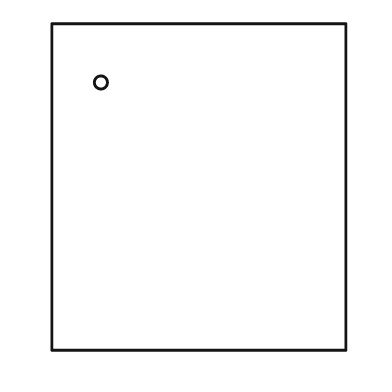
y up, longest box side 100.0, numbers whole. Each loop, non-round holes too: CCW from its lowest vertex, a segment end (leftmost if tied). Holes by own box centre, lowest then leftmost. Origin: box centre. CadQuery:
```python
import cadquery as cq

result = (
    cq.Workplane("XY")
    .moveTo(-45.0, -50.0)
    .lineTo(45.0, -50.0)
    .lineTo(45.0, 50.0)
    .lineTo(-45.0, 50.0)
    .close()
    .moveTo(-30.0, 32.0)
    .circle(2.0)
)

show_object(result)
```